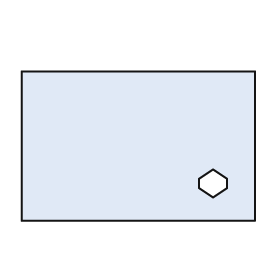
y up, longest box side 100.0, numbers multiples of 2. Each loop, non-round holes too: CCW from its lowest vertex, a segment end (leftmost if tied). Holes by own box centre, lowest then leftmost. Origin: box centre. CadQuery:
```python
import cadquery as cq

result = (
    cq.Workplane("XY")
    .moveTo(-50.0, -32.0)
    .lineTo(50.0, -32.0)
    .lineTo(50.0, 32.0)
    .lineTo(-50.0, 32.0)
    .close()
    .moveTo(32.0, -22.0)
    .lineTo(38.0, -18.0)
    .lineTo(38.0, -14.0)
    .lineTo(32.0, -10.0)
    .lineTo(26.0, -14.0)
    .lineTo(26.0, -18.0)
    .close()
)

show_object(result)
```